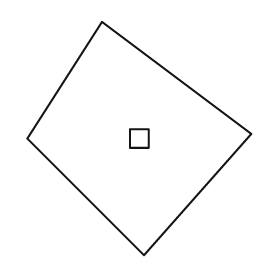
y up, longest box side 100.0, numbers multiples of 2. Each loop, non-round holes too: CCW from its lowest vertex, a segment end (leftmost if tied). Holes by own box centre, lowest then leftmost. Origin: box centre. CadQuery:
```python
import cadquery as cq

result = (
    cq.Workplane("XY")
    .moveTo(2.0, -50.0)
    .lineTo(48.0, 2.0)
    .lineTo(-16.0, 50.0)
    .lineTo(-48.0, 0.0)
    .close()
    .moveTo(-4.0, -4.0)
    .lineTo(4.0, -4.0)
    .lineTo(4.0, 4.0)
    .lineTo(-4.0, 4.0)
    .close()
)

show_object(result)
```